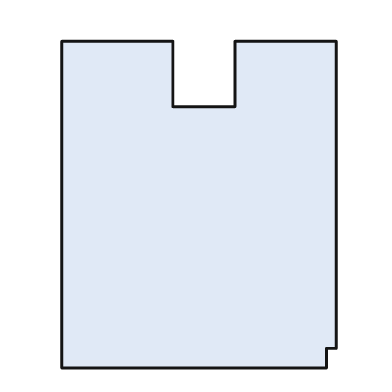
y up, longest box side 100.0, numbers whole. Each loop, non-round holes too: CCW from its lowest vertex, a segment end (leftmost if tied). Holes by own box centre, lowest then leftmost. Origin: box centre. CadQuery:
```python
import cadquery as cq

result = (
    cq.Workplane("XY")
    .moveTo(-42.0, -50.0)
    .lineTo(39.0, -50.0)
    .lineTo(39.0, -44.0)
    .lineTo(42.0, -44.0)
    .lineTo(42.0, 50.0)
    .lineTo(11.0, 50.0)
    .lineTo(11.0, 30.0)
    .lineTo(-8.0, 30.0)
    .lineTo(-8.0, 50.0)
    .lineTo(-42.0, 50.0)
    .close()
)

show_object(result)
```